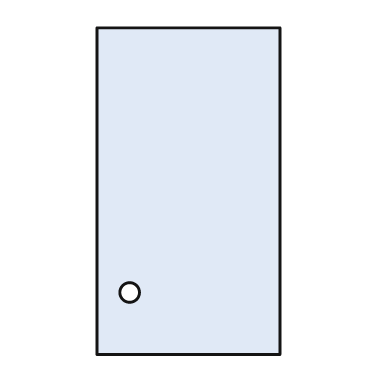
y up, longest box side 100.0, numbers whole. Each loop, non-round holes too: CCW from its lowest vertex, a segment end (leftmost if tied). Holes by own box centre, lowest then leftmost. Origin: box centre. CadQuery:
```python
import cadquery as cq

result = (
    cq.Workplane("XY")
    .moveTo(-28.0, -50.0)
    .lineTo(28.0, -50.0)
    .lineTo(28.0, 50.0)
    .lineTo(-28.0, 50.0)
    .close()
    .moveTo(-18.0, -31.0)
    .circle(3.0)
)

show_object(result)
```